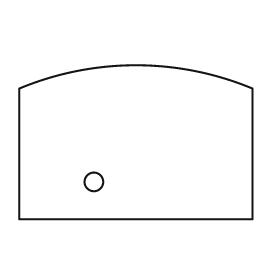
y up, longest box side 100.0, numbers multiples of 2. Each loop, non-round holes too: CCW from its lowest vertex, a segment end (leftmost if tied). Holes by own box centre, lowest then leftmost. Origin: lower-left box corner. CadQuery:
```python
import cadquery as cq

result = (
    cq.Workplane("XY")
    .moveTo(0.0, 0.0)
    .lineTo(100.0, 0.0)
    .lineTo(100.0, 56.0)
    .threePointArc((50.0, 66.0), (0.0, 56.0))
    .close()
    .moveTo(32.0, 16.0)
    .circle(4.0)
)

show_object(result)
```